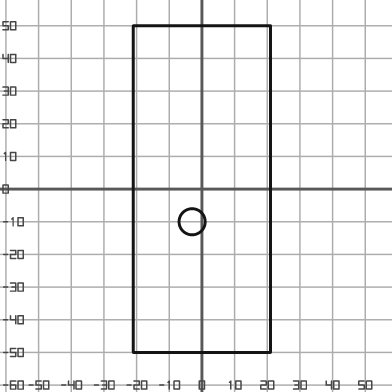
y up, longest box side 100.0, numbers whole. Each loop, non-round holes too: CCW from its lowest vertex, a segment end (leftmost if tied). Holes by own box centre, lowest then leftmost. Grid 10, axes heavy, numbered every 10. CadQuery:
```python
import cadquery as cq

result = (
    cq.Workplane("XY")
    .moveTo(-21.0, -50.0)
    .lineTo(21.0, -50.0)
    .lineTo(21.0, 50.0)
    .lineTo(-21.0, 50.0)
    .close()
    .moveTo(-3.0, -10.0)
    .circle(4.0)
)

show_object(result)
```